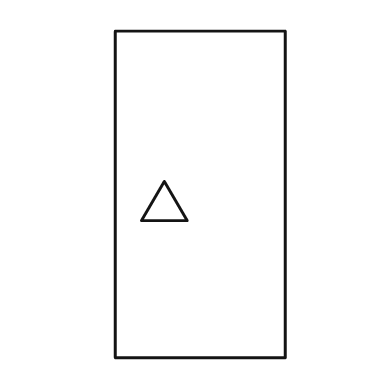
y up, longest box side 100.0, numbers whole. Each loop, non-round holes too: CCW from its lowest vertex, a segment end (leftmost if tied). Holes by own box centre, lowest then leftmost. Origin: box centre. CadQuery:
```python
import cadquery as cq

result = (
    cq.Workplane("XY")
    .moveTo(-26.0, -50.0)
    .lineTo(26.0, -50.0)
    .lineTo(26.0, 50.0)
    .lineTo(-26.0, 50.0)
    .close()
    .moveTo(-18.0, -8.0)
    .lineTo(-4.0, -8.0)
    .lineTo(-11.0, 4.0)
    .close()
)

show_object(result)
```